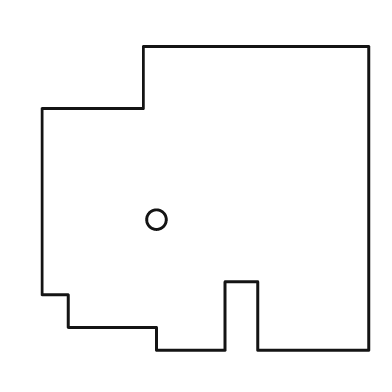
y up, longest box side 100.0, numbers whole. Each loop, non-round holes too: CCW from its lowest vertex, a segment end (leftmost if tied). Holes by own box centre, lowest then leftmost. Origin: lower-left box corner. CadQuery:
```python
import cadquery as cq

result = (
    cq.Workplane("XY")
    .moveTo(35.0, 0.0)
    .lineTo(56.0, 0.0)
    .lineTo(56.0, 21.0)
    .lineTo(66.0, 21.0)
    .lineTo(66.0, 0.0)
    .lineTo(100.0, 0.0)
    .lineTo(100.0, 93.0)
    .lineTo(31.0, 93.0)
    .lineTo(31.0, 74.0)
    .lineTo(0.0, 74.0)
    .lineTo(0.0, 17.0)
    .lineTo(8.0, 17.0)
    .lineTo(8.0, 7.0)
    .lineTo(35.0, 7.0)
    .close()
    .moveTo(35.0, 40.0)
    .circle(3.0)
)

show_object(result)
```